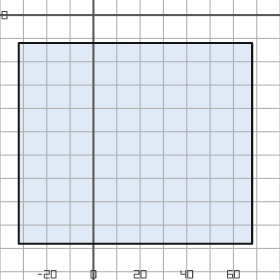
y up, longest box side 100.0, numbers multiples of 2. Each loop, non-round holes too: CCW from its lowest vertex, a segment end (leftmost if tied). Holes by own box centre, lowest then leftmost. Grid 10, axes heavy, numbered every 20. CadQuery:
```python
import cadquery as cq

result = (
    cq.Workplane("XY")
    .moveTo(-32.0, -98.0)
    .lineTo(68.0, -98.0)
    .lineTo(68.0, -12.0)
    .lineTo(-32.0, -12.0)
    .close()
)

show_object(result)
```